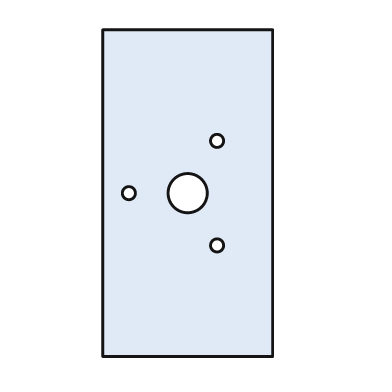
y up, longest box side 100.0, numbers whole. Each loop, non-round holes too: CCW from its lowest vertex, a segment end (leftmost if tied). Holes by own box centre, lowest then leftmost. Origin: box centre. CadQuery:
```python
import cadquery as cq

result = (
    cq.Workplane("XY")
    .moveTo(-26.0, -50.0)
    .lineTo(26.0, -50.0)
    .lineTo(26.0, 50.0)
    .lineTo(-26.0, 50.0)
    .close()
    .moveTo(9.0, -16.0)
    .circle(2.0)
    .moveTo(-18.0, 0.0)
    .circle(2.0)
    .moveTo(0.0, 0.0)
    .circle(6.0)
    .moveTo(9.0, 16.0)
    .circle(2.0)
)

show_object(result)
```